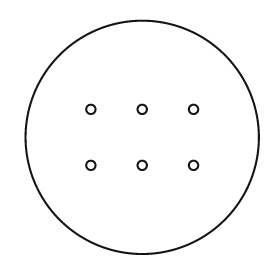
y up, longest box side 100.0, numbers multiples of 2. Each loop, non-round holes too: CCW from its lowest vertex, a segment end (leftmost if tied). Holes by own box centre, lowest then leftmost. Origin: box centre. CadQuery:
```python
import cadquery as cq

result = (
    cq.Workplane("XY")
    .moveTo(0.0, 0.0)
    .circle(50.0)
    .moveTo(-22.0, -12.0)
    .circle(2.0)
    .moveTo(0.0, -12.0)
    .circle(2.0)
    .moveTo(22.0, -12.0)
    .circle(2.0)
    .moveTo(-22.0, 12.0)
    .circle(2.0)
    .moveTo(0.0, 12.0)
    .circle(2.0)
    .moveTo(22.0, 12.0)
    .circle(2.0)
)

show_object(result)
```